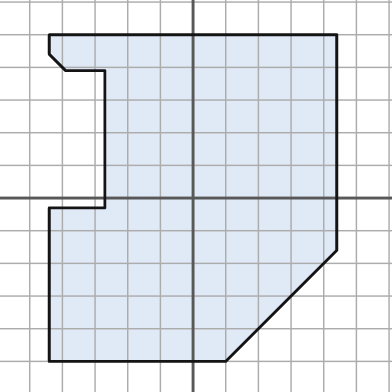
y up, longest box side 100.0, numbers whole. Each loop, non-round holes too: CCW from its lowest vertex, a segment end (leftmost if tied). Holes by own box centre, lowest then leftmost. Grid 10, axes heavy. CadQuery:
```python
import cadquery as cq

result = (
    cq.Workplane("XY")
    .moveTo(-44.0, -50.0)
    .lineTo(10.0, -50.0)
    .lineTo(44.0, -16.0)
    .lineTo(44.0, 50.0)
    .lineTo(-44.0, 50.0)
    .lineTo(-44.0, 44.0)
    .lineTo(-39.0, 39.0)
    .lineTo(-27.0, 39.0)
    .lineTo(-27.0, -3.0)
    .lineTo(-44.0, -3.0)
    .close()
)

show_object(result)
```